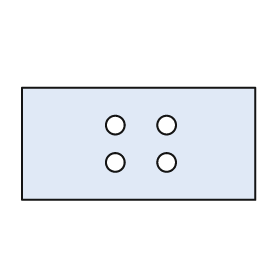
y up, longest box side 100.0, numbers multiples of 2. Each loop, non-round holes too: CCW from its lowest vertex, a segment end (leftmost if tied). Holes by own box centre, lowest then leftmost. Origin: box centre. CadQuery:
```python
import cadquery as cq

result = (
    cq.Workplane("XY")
    .moveTo(-50.0, -24.0)
    .lineTo(50.0, -24.0)
    .lineTo(50.0, 24.0)
    .lineTo(-50.0, 24.0)
    .close()
    .moveTo(-10.0, -8.0)
    .circle(4.0)
    .moveTo(12.0, -8.0)
    .circle(4.0)
    .moveTo(-10.0, 8.0)
    .circle(4.0)
    .moveTo(12.0, 8.0)
    .circle(4.0)
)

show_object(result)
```